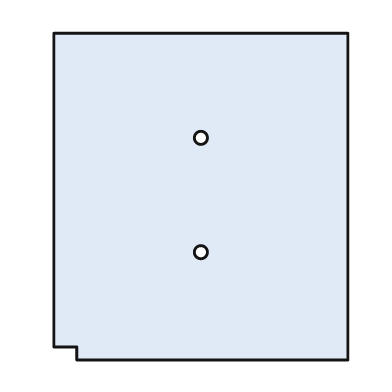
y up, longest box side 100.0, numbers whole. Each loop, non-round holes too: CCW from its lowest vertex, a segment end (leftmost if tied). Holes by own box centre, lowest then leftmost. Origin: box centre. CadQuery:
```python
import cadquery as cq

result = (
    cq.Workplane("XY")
    .moveTo(-38.0, -50.0)
    .lineTo(45.0, -50.0)
    .lineTo(45.0, 50.0)
    .lineTo(-45.0, 50.0)
    .lineTo(-45.0, -46.0)
    .lineTo(-38.0, -46.0)
    .close()
    .moveTo(0.0, -17.0)
    .circle(2.0)
    .moveTo(0.0, 18.0)
    .circle(2.0)
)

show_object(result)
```